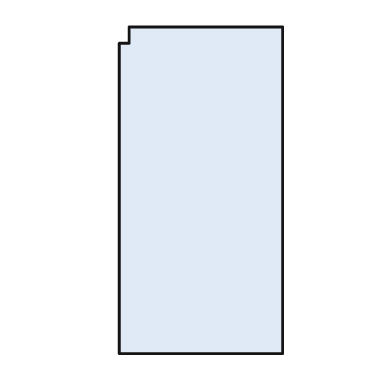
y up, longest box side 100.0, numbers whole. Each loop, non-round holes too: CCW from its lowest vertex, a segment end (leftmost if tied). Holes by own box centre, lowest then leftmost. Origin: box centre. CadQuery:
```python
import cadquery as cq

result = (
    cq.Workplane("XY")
    .moveTo(-25.0, -50.0)
    .lineTo(25.0, -50.0)
    .lineTo(25.0, 50.0)
    .lineTo(-22.0, 50.0)
    .lineTo(-22.0, 45.0)
    .lineTo(-25.0, 45.0)
    .close()
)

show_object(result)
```